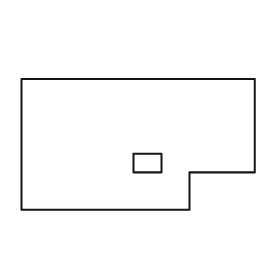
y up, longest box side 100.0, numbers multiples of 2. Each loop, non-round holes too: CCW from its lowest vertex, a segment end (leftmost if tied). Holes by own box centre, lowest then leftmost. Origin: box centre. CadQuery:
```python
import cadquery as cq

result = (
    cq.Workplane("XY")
    .moveTo(-50.0, -28.0)
    .lineTo(22.0, -28.0)
    .lineTo(22.0, -12.0)
    .lineTo(50.0, -12.0)
    .lineTo(50.0, 28.0)
    .lineTo(-50.0, 28.0)
    .close()
    .moveTo(-2.0, -12.0)
    .lineTo(10.0, -12.0)
    .lineTo(10.0, -4.0)
    .lineTo(-2.0, -4.0)
    .close()
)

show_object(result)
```